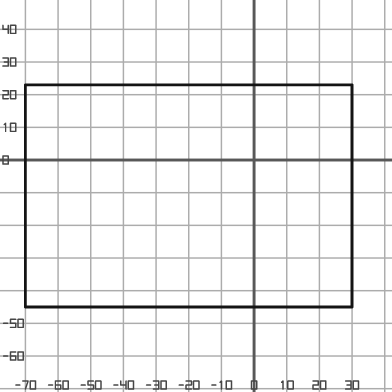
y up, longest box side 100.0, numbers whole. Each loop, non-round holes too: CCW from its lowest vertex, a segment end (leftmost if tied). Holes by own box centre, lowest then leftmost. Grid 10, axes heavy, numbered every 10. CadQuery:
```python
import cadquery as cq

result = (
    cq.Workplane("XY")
    .moveTo(-70.0, -45.0)
    .lineTo(30.0, -45.0)
    .lineTo(30.0, 23.0)
    .lineTo(-70.0, 23.0)
    .close()
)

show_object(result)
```